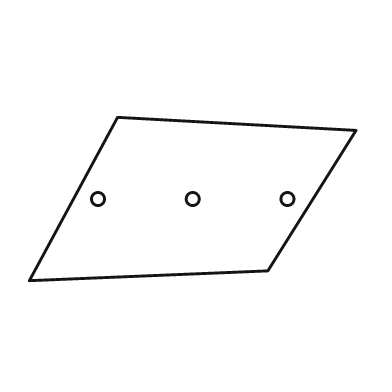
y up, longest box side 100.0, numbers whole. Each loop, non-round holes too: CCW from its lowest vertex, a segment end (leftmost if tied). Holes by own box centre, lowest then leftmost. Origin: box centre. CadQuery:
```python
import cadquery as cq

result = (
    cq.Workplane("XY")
    .moveTo(-50.0, -25.0)
    .lineTo(23.0, -22.0)
    .lineTo(50.0, 21.0)
    .lineTo(-23.0, 25.0)
    .close()
    .moveTo(-29.0, 0.0)
    .circle(2.0)
    .moveTo(0.0, 0.0)
    .circle(2.0)
    .moveTo(29.0, 0.0)
    .circle(2.0)
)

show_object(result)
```